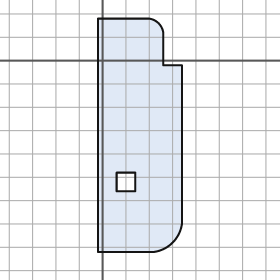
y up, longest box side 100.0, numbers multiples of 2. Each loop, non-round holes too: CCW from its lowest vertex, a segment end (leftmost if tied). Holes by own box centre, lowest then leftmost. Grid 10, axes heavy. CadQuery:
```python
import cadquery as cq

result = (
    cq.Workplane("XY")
    .moveTo(-2.0, -82.0)
    .lineTo(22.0, -82.0)
    .threePointArc((30.0, -78.0), (34.0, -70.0))
    .lineTo(34.0, -2.0)
    .lineTo(26.0, -2.0)
    .lineTo(26.0, 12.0)
    .threePointArc((24.0, 16.0), (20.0, 18.0))
    .lineTo(-2.0, 18.0)
    .close()
    .moveTo(6.0, -56.0)
    .lineTo(14.0, -56.0)
    .lineTo(14.0, -48.0)
    .lineTo(6.0, -48.0)
    .close()
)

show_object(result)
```